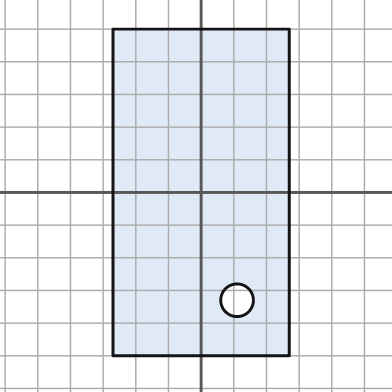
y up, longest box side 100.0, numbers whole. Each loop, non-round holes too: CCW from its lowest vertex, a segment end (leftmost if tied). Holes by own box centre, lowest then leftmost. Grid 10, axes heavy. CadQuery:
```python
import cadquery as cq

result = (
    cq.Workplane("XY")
    .moveTo(-27.0, -50.0)
    .lineTo(27.0, -50.0)
    .lineTo(27.0, 50.0)
    .lineTo(-27.0, 50.0)
    .close()
    .moveTo(11.0, -33.0)
    .circle(5.0)
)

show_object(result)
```